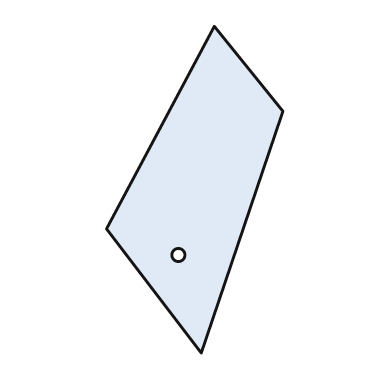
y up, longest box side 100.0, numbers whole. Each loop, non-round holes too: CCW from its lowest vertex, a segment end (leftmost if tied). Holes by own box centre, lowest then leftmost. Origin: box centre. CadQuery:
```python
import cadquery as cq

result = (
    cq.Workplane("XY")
    .moveTo(2.0, -50.0)
    .lineTo(27.0, 24.0)
    .lineTo(6.0, 50.0)
    .lineTo(-27.0, -12.0)
    .close()
    .moveTo(-5.0, -20.0)
    .circle(2.0)
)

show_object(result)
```